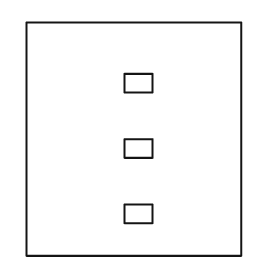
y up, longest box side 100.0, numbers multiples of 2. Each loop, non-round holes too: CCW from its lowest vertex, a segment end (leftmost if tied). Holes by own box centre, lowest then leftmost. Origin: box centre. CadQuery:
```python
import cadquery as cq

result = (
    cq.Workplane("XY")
    .moveTo(-46.0, -50.0)
    .lineTo(46.0, -50.0)
    .lineTo(46.0, 50.0)
    .lineTo(-46.0, 50.0)
    .close()
    .moveTo(-4.0, -36.0)
    .lineTo(8.0, -36.0)
    .lineTo(8.0, -28.0)
    .lineTo(-4.0, -28.0)
    .close()
    .moveTo(-4.0, -8.0)
    .lineTo(8.0, -8.0)
    .lineTo(8.0, 0.0)
    .lineTo(-4.0, 0.0)
    .close()
    .moveTo(-4.0, 20.0)
    .lineTo(8.0, 20.0)
    .lineTo(8.0, 28.0)
    .lineTo(-4.0, 28.0)
    .close()
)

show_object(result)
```